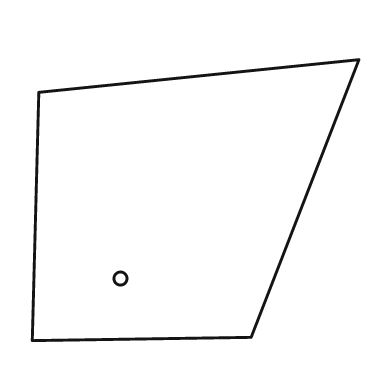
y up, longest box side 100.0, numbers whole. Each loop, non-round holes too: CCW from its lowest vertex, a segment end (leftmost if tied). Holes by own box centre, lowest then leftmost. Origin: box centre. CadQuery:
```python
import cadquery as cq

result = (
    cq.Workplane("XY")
    .moveTo(-50.0, -43.0)
    .lineTo(17.0, -42.0)
    .lineTo(50.0, 43.0)
    .lineTo(-48.0, 33.0)
    .close()
    .moveTo(-23.0, -24.0)
    .circle(2.0)
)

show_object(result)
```